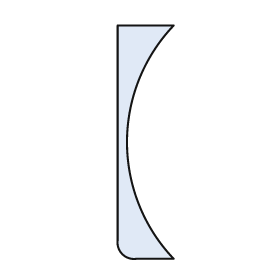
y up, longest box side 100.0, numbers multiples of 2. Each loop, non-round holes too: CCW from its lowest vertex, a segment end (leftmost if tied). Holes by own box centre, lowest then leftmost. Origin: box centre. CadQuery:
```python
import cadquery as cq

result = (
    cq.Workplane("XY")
    .moveTo(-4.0, -50.0)
    .lineTo(12.0, -50.0)
    .threePointArc((-8.0, 0.0), (12.0, 50.0))
    .lineTo(-12.0, 50.0)
    .lineTo(-12.0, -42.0)
    .threePointArc((-10.0, -48.0), (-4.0, -50.0))
    .close()
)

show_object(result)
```